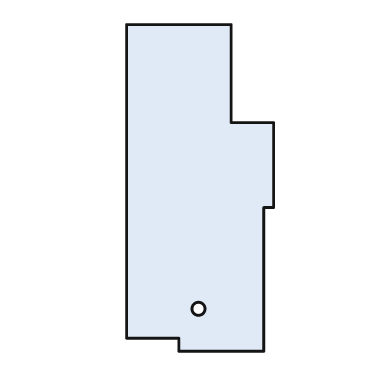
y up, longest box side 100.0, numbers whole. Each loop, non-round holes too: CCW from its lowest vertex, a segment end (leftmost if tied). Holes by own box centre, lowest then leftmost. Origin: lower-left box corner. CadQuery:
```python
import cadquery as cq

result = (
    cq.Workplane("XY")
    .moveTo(16.0, 0.0)
    .lineTo(42.0, 0.0)
    .lineTo(42.0, 44.0)
    .lineTo(45.0, 44.0)
    .lineTo(45.0, 70.0)
    .lineTo(32.0, 70.0)
    .lineTo(32.0, 100.0)
    .lineTo(0.0, 100.0)
    .lineTo(0.0, 4.0)
    .lineTo(16.0, 4.0)
    .close()
    .moveTo(22.0, 13.0)
    .circle(2.0)
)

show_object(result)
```